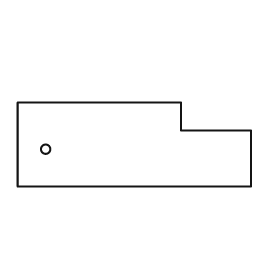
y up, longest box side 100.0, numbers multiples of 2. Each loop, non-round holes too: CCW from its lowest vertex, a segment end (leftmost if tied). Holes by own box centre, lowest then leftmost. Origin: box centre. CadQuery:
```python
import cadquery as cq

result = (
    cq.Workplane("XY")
    .moveTo(-50.0, -18.0)
    .lineTo(50.0, -18.0)
    .lineTo(50.0, 6.0)
    .lineTo(20.0, 6.0)
    .lineTo(20.0, 18.0)
    .lineTo(-50.0, 18.0)
    .close()
    .moveTo(-38.0, -2.0)
    .circle(2.0)
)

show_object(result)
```